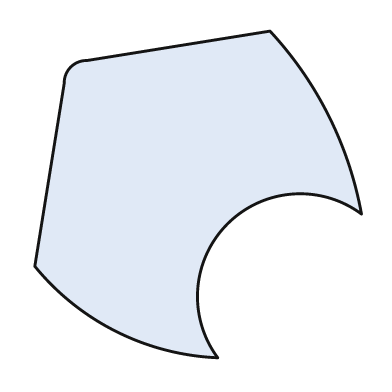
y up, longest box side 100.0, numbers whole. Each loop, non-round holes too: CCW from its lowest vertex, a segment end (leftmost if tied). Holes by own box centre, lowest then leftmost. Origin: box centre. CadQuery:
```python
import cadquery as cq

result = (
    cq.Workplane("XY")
    .moveTo(6.0, -50.0)
    .threePointArc((9.0, -9.0), (50.0, -6.0))
    .threePointArc((40.0, 24.0), (22.0, 50.0))
    .lineTo(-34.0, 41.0)
    .threePointArc((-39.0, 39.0), (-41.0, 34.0))
    .lineTo(-50.0, -22.0)
    .threePointArc((-25.0, -42.0), (6.0, -50.0))
    .close()
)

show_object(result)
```